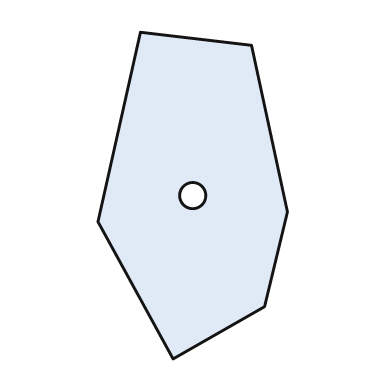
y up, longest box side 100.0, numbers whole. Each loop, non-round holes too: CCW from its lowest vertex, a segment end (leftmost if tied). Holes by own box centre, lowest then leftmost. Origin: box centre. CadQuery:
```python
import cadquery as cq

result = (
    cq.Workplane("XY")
    .moveTo(-6.0, -50.0)
    .lineTo(22.0, -34.0)
    .lineTo(29.0, -5.0)
    .lineTo(18.0, 46.0)
    .lineTo(-16.0, 50.0)
    .lineTo(-29.0, -8.0)
    .close()
    .moveTo(0.0, 0.0)
    .circle(4.0)
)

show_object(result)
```